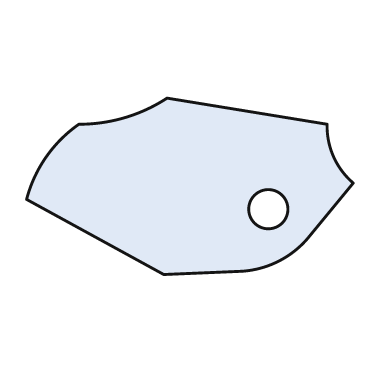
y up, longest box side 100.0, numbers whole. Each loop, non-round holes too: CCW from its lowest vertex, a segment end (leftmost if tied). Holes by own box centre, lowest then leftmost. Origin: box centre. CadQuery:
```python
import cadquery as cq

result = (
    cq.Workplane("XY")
    .moveTo(-8.0, -27.0)
    .lineTo(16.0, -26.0)
    .threePointArc((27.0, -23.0), (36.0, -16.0))
    .lineTo(50.0, 1.0)
    .threePointArc((44.0, 9.0), (42.0, 19.0))
    .lineTo(-7.0, 27.0)
    .threePointArc((-20.0, 21.0), (-34.0, 19.0))
    .threePointArc((-44.0, 9.0), (-50.0, -4.0))
    .close()
    .moveTo(24.0, -7.0)
    .circle(6.0)
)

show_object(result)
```